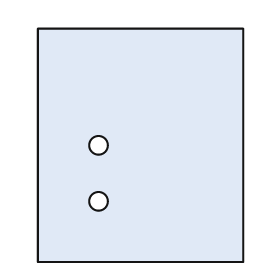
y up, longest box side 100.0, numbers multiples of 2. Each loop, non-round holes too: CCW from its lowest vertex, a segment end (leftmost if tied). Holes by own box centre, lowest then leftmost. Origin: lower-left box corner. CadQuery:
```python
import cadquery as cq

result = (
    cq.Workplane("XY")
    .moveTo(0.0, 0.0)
    .lineTo(88.0, 0.0)
    .lineTo(88.0, 100.0)
    .lineTo(0.0, 100.0)
    .close()
    .moveTo(26.0, 26.0)
    .circle(4.0)
    .moveTo(26.0, 50.0)
    .circle(4.0)
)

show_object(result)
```